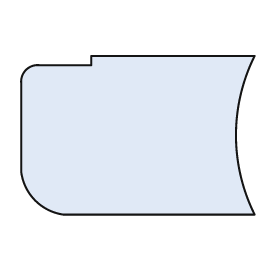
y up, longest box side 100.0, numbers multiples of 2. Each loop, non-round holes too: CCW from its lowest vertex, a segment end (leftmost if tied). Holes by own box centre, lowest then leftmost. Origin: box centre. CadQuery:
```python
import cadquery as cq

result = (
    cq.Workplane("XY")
    .moveTo(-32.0, -34.0)
    .lineTo(50.0, -34.0)
    .threePointArc((42.0, 0.0), (50.0, 34.0))
    .lineTo(-20.0, 34.0)
    .lineTo(-20.0, 30.0)
    .lineTo(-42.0, 30.0)
    .threePointArc((-48.0, 28.0), (-50.0, 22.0))
    .lineTo(-50.0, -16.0)
    .threePointArc((-44.0, -28.0), (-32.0, -34.0))
    .close()
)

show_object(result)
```